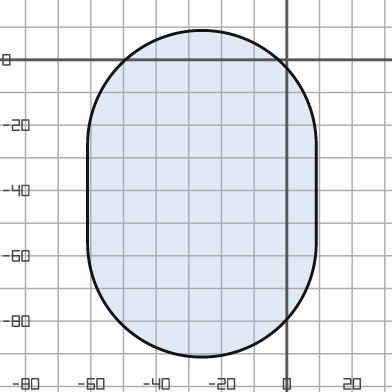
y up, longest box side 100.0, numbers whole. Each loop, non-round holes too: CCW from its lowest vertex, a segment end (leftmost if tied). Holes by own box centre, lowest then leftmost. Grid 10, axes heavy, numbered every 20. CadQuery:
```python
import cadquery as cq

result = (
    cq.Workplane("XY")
    .moveTo(-61.0, -56.0)
    .threePointArc((-26.0, -91.0), (9.0, -56.0))
    .lineTo(9.0, -26.0)
    .threePointArc((-26.0, 9.0), (-61.0, -26.0))
    .close()
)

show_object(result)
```